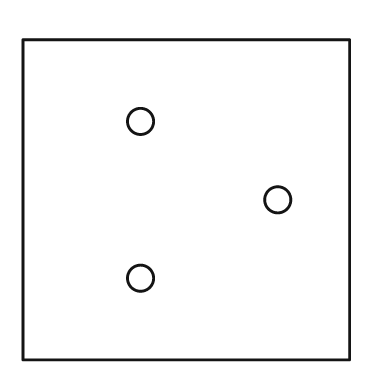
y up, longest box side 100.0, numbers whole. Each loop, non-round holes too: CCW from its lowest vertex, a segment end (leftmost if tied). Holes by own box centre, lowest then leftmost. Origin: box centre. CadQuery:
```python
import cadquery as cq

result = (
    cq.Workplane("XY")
    .moveTo(-50.0, -49.0)
    .lineTo(50.0, -49.0)
    .lineTo(50.0, 49.0)
    .lineTo(-50.0, 49.0)
    .close()
    .moveTo(-14.0, -24.0)
    .circle(4.0)
    .moveTo(28.0, 0.0)
    .circle(4.0)
    .moveTo(-14.0, 24.0)
    .circle(4.0)
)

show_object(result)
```